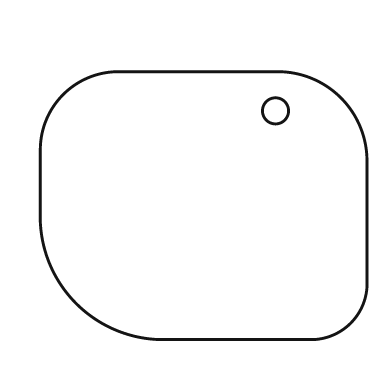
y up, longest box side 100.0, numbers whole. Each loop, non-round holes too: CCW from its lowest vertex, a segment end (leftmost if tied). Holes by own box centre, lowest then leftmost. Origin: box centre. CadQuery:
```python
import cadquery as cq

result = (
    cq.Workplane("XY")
    .moveTo(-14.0, -41.0)
    .lineTo(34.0, -41.0)
    .threePointArc((45.0, -36.0), (50.0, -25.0))
    .lineTo(50.0, 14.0)
    .threePointArc((42.0, 33.0), (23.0, 41.0))
    .lineTo(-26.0, 41.0)
    .threePointArc((-43.0, 34.0), (-50.0, 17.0))
    .lineTo(-50.0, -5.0)
    .threePointArc((-39.0, -30.0), (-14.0, -41.0))
    .close()
    .moveTo(22.0, 29.0)
    .circle(4.0)
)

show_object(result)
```